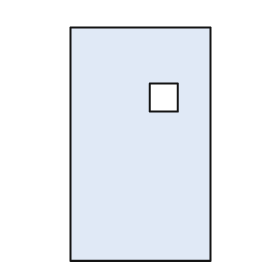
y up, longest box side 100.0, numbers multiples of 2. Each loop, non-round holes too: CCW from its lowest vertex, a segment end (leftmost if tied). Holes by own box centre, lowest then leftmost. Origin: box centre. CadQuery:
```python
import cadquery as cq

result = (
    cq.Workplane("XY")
    .moveTo(-30.0, -50.0)
    .lineTo(30.0, -50.0)
    .lineTo(30.0, 50.0)
    .lineTo(-30.0, 50.0)
    .close()
    .moveTo(4.0, 14.0)
    .lineTo(16.0, 14.0)
    .lineTo(16.0, 26.0)
    .lineTo(4.0, 26.0)
    .close()
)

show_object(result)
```